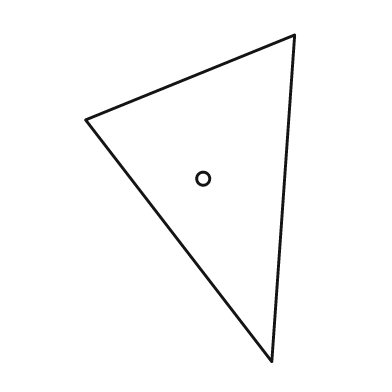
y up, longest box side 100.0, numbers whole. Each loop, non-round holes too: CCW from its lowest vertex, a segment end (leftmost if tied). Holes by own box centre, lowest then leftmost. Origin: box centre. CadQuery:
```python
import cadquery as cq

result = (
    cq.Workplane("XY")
    .moveTo(25.0, -50.0)
    .lineTo(32.0, 50.0)
    .lineTo(-32.0, 24.0)
    .close()
    .moveTo(4.0, 6.0)
    .circle(2.0)
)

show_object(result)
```